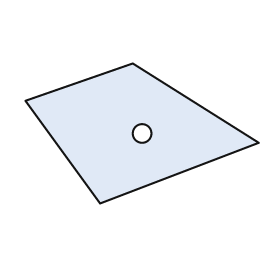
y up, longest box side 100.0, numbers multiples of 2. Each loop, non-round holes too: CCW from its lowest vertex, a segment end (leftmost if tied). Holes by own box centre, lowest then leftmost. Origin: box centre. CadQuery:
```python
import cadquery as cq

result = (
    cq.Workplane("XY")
    .moveTo(-18.0, -30.0)
    .lineTo(50.0, -4.0)
    .lineTo(-4.0, 30.0)
    .lineTo(-50.0, 14.0)
    .close()
    .moveTo(0.0, 0.0)
    .circle(4.0)
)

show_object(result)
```